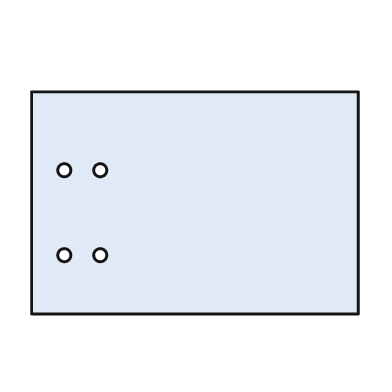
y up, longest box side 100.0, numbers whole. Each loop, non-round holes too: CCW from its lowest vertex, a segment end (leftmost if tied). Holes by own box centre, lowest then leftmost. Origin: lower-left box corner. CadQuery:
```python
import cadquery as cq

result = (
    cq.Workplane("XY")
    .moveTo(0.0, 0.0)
    .lineTo(100.0, 0.0)
    .lineTo(100.0, 68.0)
    .lineTo(0.0, 68.0)
    .close()
    .moveTo(10.0, 18.0)
    .circle(2.0)
    .moveTo(21.0, 18.0)
    .circle(2.0)
    .moveTo(10.0, 44.0)
    .circle(2.0)
    .moveTo(21.0, 44.0)
    .circle(2.0)
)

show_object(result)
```